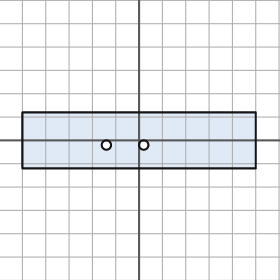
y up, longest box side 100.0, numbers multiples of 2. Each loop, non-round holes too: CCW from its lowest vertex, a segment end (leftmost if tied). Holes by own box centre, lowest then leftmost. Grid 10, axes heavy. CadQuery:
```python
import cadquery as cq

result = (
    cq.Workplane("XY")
    .moveTo(-50.0, -12.0)
    .lineTo(50.0, -12.0)
    .lineTo(50.0, 12.0)
    .lineTo(-50.0, 12.0)
    .close()
    .moveTo(-14.0, -2.0)
    .circle(2.0)
    .moveTo(2.0, -2.0)
    .circle(2.0)
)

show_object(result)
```